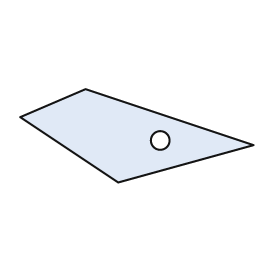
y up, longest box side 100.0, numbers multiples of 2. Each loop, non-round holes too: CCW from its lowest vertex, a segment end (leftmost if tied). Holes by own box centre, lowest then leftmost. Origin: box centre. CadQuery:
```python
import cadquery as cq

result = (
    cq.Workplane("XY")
    .moveTo(-8.0, -20.0)
    .lineTo(50.0, -4.0)
    .lineTo(-22.0, 20.0)
    .lineTo(-50.0, 8.0)
    .close()
    .moveTo(10.0, -2.0)
    .circle(4.0)
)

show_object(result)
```